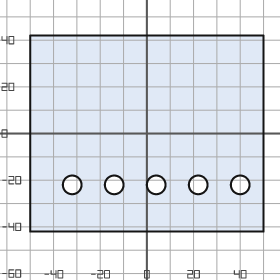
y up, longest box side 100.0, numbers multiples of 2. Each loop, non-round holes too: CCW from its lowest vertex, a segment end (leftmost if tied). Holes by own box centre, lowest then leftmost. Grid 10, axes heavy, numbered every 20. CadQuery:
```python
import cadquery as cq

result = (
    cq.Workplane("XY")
    .moveTo(-50.0, -42.0)
    .lineTo(50.0, -42.0)
    .lineTo(50.0, 42.0)
    .lineTo(-50.0, 42.0)
    .close()
    .moveTo(-32.0, -22.0)
    .circle(4.0)
    .moveTo(-14.0, -22.0)
    .circle(4.0)
    .moveTo(4.0, -22.0)
    .circle(4.0)
    .moveTo(22.0, -22.0)
    .circle(4.0)
    .moveTo(40.0, -22.0)
    .circle(4.0)
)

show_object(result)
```